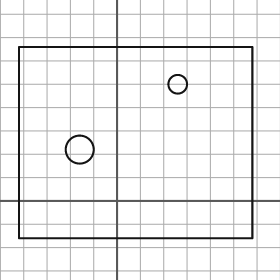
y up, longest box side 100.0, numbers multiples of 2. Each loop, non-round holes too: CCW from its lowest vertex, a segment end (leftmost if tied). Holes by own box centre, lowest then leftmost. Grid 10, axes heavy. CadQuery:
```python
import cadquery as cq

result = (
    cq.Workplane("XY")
    .moveTo(-42.0, -16.0)
    .lineTo(58.0, -16.0)
    .lineTo(58.0, 66.0)
    .lineTo(-42.0, 66.0)
    .close()
    .moveTo(-16.0, 22.0)
    .circle(6.0)
    .moveTo(26.0, 50.0)
    .circle(4.0)
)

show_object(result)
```